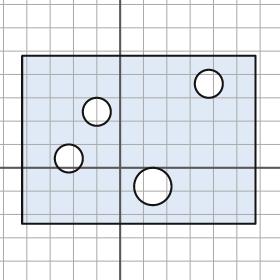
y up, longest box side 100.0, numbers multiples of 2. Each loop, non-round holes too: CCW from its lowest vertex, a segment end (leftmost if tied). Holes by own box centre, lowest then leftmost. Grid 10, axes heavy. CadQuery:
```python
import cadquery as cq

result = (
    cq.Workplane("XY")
    .moveTo(-42.0, -24.0)
    .lineTo(58.0, -24.0)
    .lineTo(58.0, 48.0)
    .lineTo(-42.0, 48.0)
    .close()
    .moveTo(14.0, -8.0)
    .circle(8.0)
    .moveTo(-22.0, 4.0)
    .circle(6.0)
    .moveTo(-10.0, 24.0)
    .circle(6.0)
    .moveTo(38.0, 36.0)
    .circle(6.0)
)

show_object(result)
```